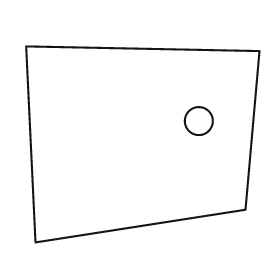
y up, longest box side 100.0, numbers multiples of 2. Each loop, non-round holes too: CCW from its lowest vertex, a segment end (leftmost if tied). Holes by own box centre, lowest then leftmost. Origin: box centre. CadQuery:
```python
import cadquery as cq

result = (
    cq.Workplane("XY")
    .moveTo(-46.0, -42.0)
    .lineTo(44.0, -28.0)
    .lineTo(50.0, 40.0)
    .lineTo(-50.0, 42.0)
    .close()
    .moveTo(24.0, 10.0)
    .circle(6.0)
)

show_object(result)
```